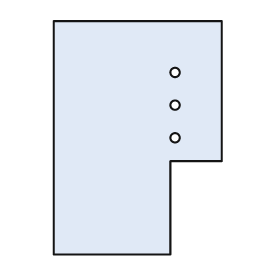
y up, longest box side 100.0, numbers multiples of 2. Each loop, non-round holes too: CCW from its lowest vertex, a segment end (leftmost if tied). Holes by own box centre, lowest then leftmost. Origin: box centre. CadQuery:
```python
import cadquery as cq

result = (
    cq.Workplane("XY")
    .moveTo(-36.0, -50.0)
    .lineTo(14.0, -50.0)
    .lineTo(14.0, -10.0)
    .lineTo(36.0, -10.0)
    .lineTo(36.0, 50.0)
    .lineTo(-36.0, 50.0)
    .close()
    .moveTo(16.0, 0.0)
    .circle(2.0)
    .moveTo(16.0, 14.0)
    .circle(2.0)
    .moveTo(16.0, 28.0)
    .circle(2.0)
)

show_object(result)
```